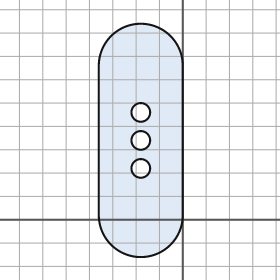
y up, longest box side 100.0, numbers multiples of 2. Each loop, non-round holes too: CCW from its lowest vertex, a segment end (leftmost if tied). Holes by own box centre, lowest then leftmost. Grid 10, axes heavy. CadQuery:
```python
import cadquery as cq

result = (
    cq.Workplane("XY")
    .moveTo(-36.0, 2.0)
    .threePointArc((-18.0, -16.0), (0.0, 2.0))
    .lineTo(0.0, 66.0)
    .threePointArc((-18.0, 84.0), (-36.0, 66.0))
    .close()
    .moveTo(-18.0, 22.0)
    .circle(4.0)
    .moveTo(-18.0, 34.0)
    .circle(4.0)
    .moveTo(-18.0, 46.0)
    .circle(4.0)
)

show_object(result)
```